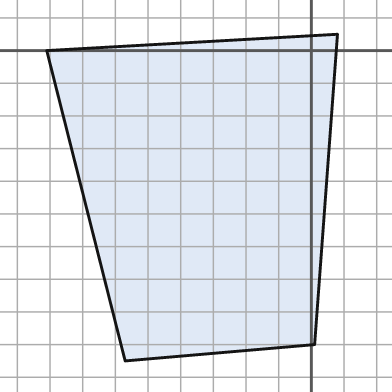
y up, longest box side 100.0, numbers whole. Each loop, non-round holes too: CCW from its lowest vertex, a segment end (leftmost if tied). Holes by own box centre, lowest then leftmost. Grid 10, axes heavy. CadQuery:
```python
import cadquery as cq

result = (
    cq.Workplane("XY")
    .moveTo(-57.0, -95.0)
    .lineTo(1.0, -90.0)
    .lineTo(8.0, 5.0)
    .lineTo(-81.0, 0.0)
    .close()
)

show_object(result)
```